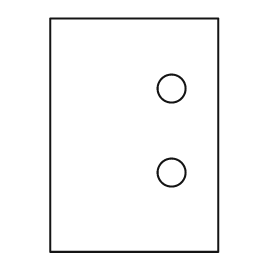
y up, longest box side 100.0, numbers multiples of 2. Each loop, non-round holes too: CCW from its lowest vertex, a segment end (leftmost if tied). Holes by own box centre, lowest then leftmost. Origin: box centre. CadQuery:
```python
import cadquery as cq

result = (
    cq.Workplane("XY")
    .moveTo(-36.0, -50.0)
    .lineTo(36.0, -50.0)
    .lineTo(36.0, 50.0)
    .lineTo(-36.0, 50.0)
    .close()
    .moveTo(16.0, -16.0)
    .circle(6.0)
    .moveTo(16.0, 20.0)
    .circle(6.0)
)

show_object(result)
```